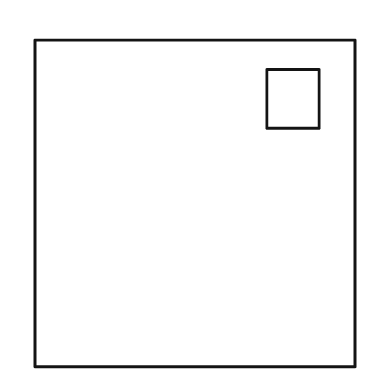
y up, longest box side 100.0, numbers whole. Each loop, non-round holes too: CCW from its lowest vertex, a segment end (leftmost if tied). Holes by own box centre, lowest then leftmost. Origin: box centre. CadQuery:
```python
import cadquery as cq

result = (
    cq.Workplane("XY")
    .moveTo(-49.0, -50.0)
    .lineTo(49.0, -50.0)
    .lineTo(49.0, 50.0)
    .lineTo(-49.0, 50.0)
    .close()
    .moveTo(22.0, 23.0)
    .lineTo(38.0, 23.0)
    .lineTo(38.0, 41.0)
    .lineTo(22.0, 41.0)
    .close()
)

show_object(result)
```